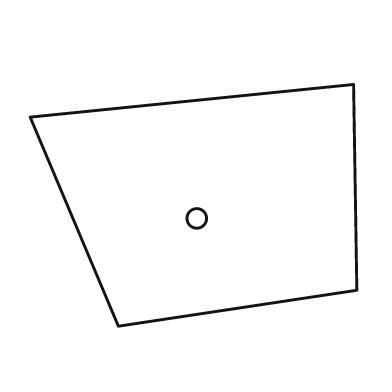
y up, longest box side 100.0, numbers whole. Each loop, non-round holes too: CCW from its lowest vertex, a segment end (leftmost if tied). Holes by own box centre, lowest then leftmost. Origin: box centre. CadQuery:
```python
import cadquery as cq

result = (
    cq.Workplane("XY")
    .moveTo(-23.0, -37.0)
    .lineTo(50.0, -26.0)
    .lineTo(49.0, 37.0)
    .lineTo(-50.0, 27.0)
    .close()
    .moveTo(1.0, -4.0)
    .circle(3.0)
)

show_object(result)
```